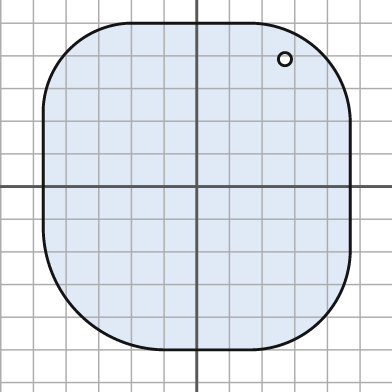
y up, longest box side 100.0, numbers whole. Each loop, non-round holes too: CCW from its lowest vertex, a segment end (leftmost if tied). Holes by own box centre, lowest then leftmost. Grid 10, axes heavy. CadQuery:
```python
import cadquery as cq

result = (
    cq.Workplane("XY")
    .moveTo(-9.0, -50.0)
    .lineTo(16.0, -50.0)
    .threePointArc((38.0, -41.0), (47.0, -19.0))
    .lineTo(47.0, 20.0)
    .threePointArc((38.0, 41.0), (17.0, 50.0))
    .lineTo(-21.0, 50.0)
    .threePointArc((-39.0, 42.0), (-47.0, 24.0))
    .lineTo(-47.0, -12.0)
    .threePointArc((-36.0, -39.0), (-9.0, -50.0))
    .close()
    .moveTo(27.0, 39.0)
    .circle(2.0)
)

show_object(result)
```